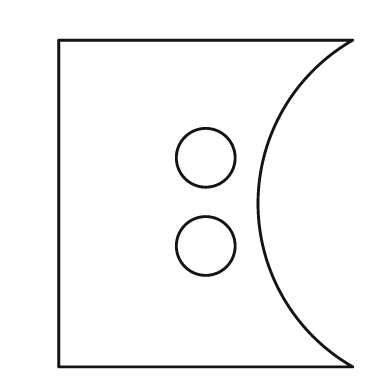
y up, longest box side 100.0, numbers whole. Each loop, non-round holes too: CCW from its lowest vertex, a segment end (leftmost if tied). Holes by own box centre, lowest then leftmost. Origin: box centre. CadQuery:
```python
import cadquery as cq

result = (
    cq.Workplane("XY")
    .moveTo(-45.0, -50.0)
    .lineTo(45.0, -50.0)
    .threePointArc((16.0, 0.0), (45.0, 50.0))
    .lineTo(-45.0, 50.0)
    .close()
    .moveTo(0.0, -13.0)
    .circle(9.0)
    .moveTo(0.0, 14.0)
    .circle(9.0)
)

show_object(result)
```